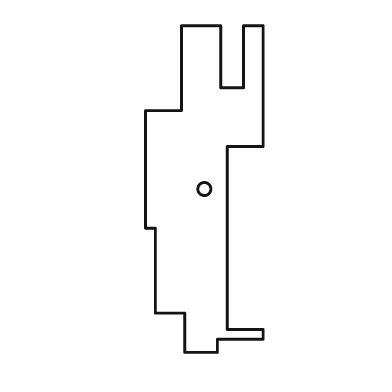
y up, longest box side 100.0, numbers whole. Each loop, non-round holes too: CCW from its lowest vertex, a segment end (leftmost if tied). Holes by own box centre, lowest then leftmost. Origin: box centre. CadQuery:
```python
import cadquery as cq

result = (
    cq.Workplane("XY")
    .moveTo(-6.0, -50.0)
    .lineTo(4.0, -50.0)
    .lineTo(4.0, -46.0)
    .lineTo(18.0, -46.0)
    .lineTo(18.0, -43.0)
    .lineTo(7.0, -43.0)
    .lineTo(7.0, 13.0)
    .lineTo(18.0, 13.0)
    .lineTo(18.0, 50.0)
    .lineTo(12.0, 50.0)
    .lineTo(12.0, 31.0)
    .lineTo(5.0, 31.0)
    .lineTo(5.0, 50.0)
    .lineTo(-7.0, 50.0)
    .lineTo(-7.0, 24.0)
    .lineTo(-18.0, 24.0)
    .lineTo(-18.0, -12.0)
    .lineTo(-15.0, -12.0)
    .lineTo(-15.0, -38.0)
    .lineTo(-6.0, -38.0)
    .close()
    .moveTo(0.0, 0.0)
    .circle(2.0)
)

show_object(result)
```